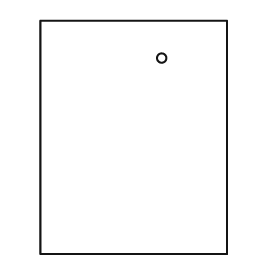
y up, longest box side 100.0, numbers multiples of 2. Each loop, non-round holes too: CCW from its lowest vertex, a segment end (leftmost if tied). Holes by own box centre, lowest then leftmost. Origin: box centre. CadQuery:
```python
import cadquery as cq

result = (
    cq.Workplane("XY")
    .moveTo(-40.0, -50.0)
    .lineTo(40.0, -50.0)
    .lineTo(40.0, 50.0)
    .lineTo(-40.0, 50.0)
    .close()
    .moveTo(12.0, 34.0)
    .circle(2.0)
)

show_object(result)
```